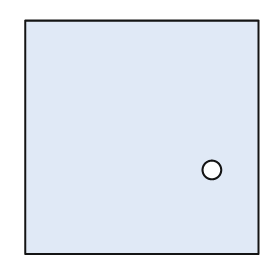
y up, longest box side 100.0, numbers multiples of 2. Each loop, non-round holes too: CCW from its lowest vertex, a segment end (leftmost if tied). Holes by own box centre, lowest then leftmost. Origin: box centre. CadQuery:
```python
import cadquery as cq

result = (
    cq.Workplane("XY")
    .moveTo(-50.0, -50.0)
    .lineTo(50.0, -50.0)
    .lineTo(50.0, 50.0)
    .lineTo(-50.0, 50.0)
    .close()
    .moveTo(30.0, -14.0)
    .circle(4.0)
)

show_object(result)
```